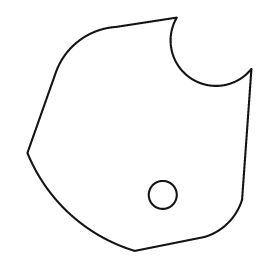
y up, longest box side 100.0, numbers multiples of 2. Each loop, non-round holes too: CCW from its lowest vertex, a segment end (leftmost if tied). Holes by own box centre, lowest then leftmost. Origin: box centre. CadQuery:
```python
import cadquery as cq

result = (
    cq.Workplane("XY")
    .moveTo(-2.0, -50.0)
    .lineTo(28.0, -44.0)
    .threePointArc((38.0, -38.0), (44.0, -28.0))
    .lineTo(48.0, 28.0)
    .threePointArc((22.0, 24.0), (16.0, 50.0))
    .lineTo(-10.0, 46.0)
    .threePointArc((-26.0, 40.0), (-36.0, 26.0))
    .lineTo(-48.0, -8.0)
    .threePointArc((-30.0, -34.0), (-2.0, -50.0))
    .close()
    .moveTo(10.0, -26.0)
    .circle(6.0)
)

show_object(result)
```